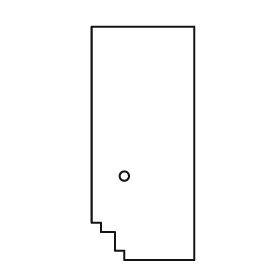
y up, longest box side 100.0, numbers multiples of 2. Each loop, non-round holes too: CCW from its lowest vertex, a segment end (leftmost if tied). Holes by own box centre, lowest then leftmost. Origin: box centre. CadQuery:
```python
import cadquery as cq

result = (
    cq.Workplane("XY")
    .moveTo(-8.0, -50.0)
    .lineTo(22.0, -50.0)
    .lineTo(22.0, 50.0)
    .lineTo(-22.0, 50.0)
    .lineTo(-22.0, -34.0)
    .lineTo(-18.0, -34.0)
    .lineTo(-18.0, -38.0)
    .lineTo(-12.0, -38.0)
    .lineTo(-12.0, -46.0)
    .lineTo(-8.0, -46.0)
    .close()
    .moveTo(-8.0, -14.0)
    .circle(2.0)
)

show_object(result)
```